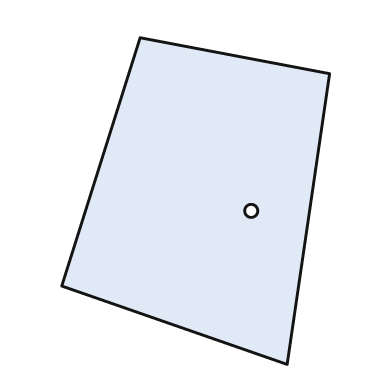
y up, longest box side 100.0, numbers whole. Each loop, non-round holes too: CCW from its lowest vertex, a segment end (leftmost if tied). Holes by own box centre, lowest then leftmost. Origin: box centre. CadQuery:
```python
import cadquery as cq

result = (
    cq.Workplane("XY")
    .moveTo(28.0, -50.0)
    .lineTo(41.0, 39.0)
    .lineTo(-17.0, 50.0)
    .lineTo(-41.0, -26.0)
    .close()
    .moveTo(17.0, -3.0)
    .circle(2.0)
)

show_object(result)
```